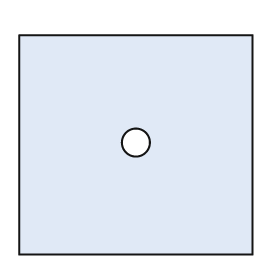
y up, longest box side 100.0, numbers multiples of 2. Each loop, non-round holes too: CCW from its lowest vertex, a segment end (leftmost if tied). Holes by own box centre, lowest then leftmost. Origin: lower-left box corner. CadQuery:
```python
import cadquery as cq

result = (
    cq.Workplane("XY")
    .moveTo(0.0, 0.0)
    .lineTo(100.0, 0.0)
    .lineTo(100.0, 94.0)
    .lineTo(0.0, 94.0)
    .close()
    .moveTo(50.0, 48.0)
    .circle(6.0)
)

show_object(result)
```